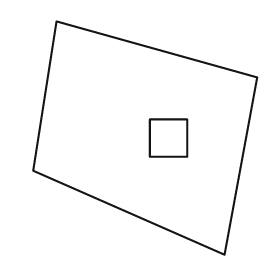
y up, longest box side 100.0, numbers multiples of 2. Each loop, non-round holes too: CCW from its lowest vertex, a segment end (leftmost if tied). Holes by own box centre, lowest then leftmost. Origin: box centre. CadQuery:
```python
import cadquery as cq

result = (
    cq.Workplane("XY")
    .moveTo(34.0, -50.0)
    .lineTo(48.0, 26.0)
    .lineTo(-38.0, 50.0)
    .lineTo(-48.0, -14.0)
    .close()
    .moveTo(2.0, -8.0)
    .lineTo(18.0, -8.0)
    .lineTo(18.0, 8.0)
    .lineTo(2.0, 8.0)
    .close()
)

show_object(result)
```